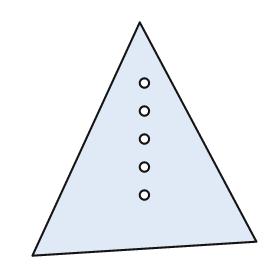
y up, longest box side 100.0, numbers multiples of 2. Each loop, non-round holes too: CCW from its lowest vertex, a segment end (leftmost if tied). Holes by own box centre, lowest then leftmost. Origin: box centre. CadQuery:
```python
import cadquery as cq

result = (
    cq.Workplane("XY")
    .moveTo(-48.0, -50.0)
    .lineTo(48.0, -44.0)
    .lineTo(-2.0, 50.0)
    .close()
    .moveTo(0.0, -24.0)
    .circle(2.0)
    .moveTo(0.0, -12.0)
    .circle(2.0)
    .moveTo(0.0, 0.0)
    .circle(2.0)
    .moveTo(0.0, 12.0)
    .circle(2.0)
    .moveTo(0.0, 24.0)
    .circle(2.0)
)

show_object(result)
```